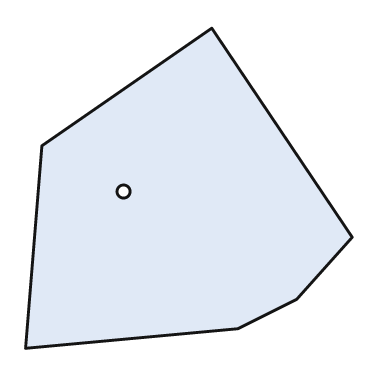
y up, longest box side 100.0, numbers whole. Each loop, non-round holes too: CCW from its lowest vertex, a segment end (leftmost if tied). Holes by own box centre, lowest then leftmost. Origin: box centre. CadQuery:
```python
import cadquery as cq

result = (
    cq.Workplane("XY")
    .moveTo(-50.0, -49.0)
    .lineTo(15.0, -43.0)
    .lineTo(33.0, -34.0)
    .lineTo(50.0, -15.0)
    .lineTo(7.0, 49.0)
    .lineTo(-45.0, 13.0)
    .close()
    .moveTo(-20.0, -1.0)
    .circle(2.0)
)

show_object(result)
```